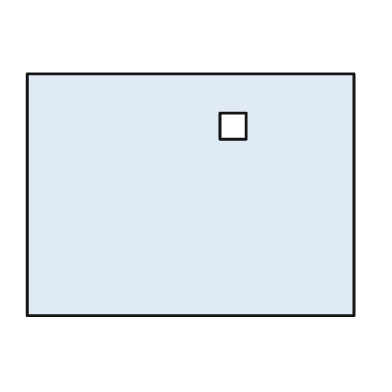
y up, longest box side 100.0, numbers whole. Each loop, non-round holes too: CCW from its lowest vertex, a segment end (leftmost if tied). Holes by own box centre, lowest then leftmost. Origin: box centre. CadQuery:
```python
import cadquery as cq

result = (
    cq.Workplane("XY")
    .moveTo(-50.0, -37.0)
    .lineTo(50.0, -37.0)
    .lineTo(50.0, 37.0)
    .lineTo(-50.0, 37.0)
    .close()
    .moveTo(9.0, 17.0)
    .lineTo(17.0, 17.0)
    .lineTo(17.0, 25.0)
    .lineTo(9.0, 25.0)
    .close()
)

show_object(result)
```